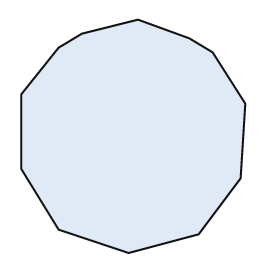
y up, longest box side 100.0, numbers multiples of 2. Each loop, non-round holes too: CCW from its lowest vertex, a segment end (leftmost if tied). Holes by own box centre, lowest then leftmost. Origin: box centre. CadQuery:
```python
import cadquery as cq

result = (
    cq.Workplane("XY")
    .moveTo(-2.0, -50.0)
    .lineTo(28.0, -42.0)
    .lineTo(46.0, -18.0)
    .lineTo(48.0, 14.0)
    .lineTo(34.0, 36.0)
    .lineTo(24.0, 42.0)
    .lineTo(2.0, 50.0)
    .lineTo(-22.0, 44.0)
    .lineTo(-32.0, 38.0)
    .lineTo(-48.0, 18.0)
    .lineTo(-48.0, -14.0)
    .lineTo(-32.0, -40.0)
    .close()
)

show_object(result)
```